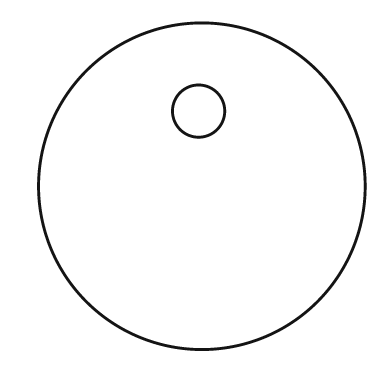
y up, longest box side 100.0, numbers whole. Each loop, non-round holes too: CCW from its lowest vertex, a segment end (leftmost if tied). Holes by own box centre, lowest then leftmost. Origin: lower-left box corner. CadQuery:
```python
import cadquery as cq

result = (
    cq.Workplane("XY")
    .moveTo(50.0, 50.0)
    .circle(50.0)
    .moveTo(49.0, 73.0)
    .circle(8.0)
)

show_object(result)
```